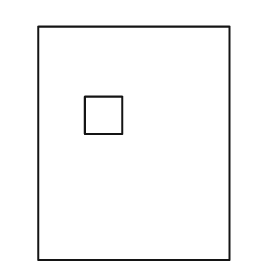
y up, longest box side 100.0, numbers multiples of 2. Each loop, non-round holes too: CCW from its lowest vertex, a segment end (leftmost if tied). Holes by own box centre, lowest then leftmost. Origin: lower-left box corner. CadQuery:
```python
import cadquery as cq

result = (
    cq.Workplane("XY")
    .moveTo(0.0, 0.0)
    .lineTo(82.0, 0.0)
    .lineTo(82.0, 100.0)
    .lineTo(0.0, 100.0)
    .close()
    .moveTo(20.0, 54.0)
    .lineTo(36.0, 54.0)
    .lineTo(36.0, 70.0)
    .lineTo(20.0, 70.0)
    .close()
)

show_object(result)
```